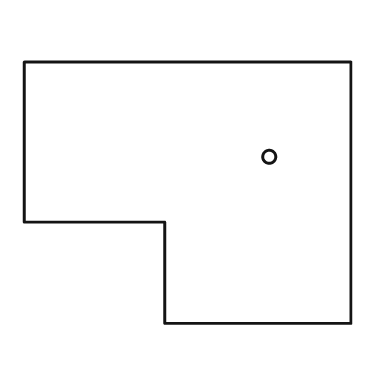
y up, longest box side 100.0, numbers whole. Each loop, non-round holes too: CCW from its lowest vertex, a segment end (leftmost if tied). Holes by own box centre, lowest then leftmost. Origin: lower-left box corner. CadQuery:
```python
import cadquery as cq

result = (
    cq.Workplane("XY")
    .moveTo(43.0, 0.0)
    .lineTo(100.0, 0.0)
    .lineTo(100.0, 80.0)
    .lineTo(0.0, 80.0)
    .lineTo(0.0, 31.0)
    .lineTo(43.0, 31.0)
    .close()
    .moveTo(75.0, 51.0)
    .circle(2.0)
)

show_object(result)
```